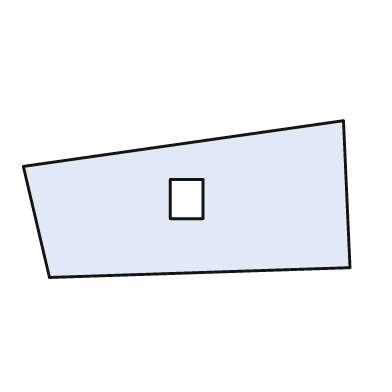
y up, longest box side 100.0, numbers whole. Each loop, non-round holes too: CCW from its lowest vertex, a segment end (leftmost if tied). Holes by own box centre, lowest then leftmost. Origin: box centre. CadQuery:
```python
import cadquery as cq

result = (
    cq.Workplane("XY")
    .moveTo(-42.0, -24.0)
    .lineTo(50.0, -21.0)
    .lineTo(48.0, 24.0)
    .lineTo(-50.0, 10.0)
    .close()
    .moveTo(-5.0, -6.0)
    .lineTo(5.0, -6.0)
    .lineTo(5.0, 6.0)
    .lineTo(-5.0, 6.0)
    .close()
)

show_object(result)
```